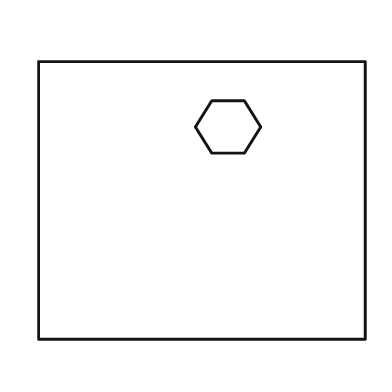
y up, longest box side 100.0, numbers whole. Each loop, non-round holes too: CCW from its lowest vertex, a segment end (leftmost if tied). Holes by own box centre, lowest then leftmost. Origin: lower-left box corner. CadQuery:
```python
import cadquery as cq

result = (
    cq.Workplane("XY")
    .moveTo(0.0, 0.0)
    .lineTo(100.0, 0.0)
    .lineTo(100.0, 85.0)
    .lineTo(0.0, 85.0)
    .close()
    .moveTo(53.0, 57.0)
    .lineTo(63.0, 57.0)
    .lineTo(68.0, 65.0)
    .lineTo(63.0, 73.0)
    .lineTo(53.0, 73.0)
    .lineTo(48.0, 65.0)
    .close()
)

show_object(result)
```